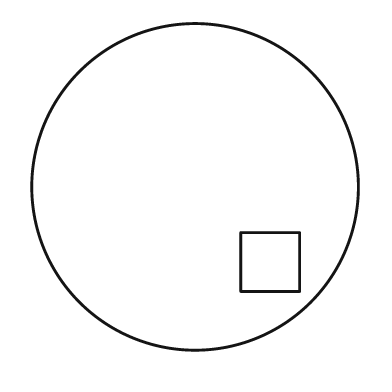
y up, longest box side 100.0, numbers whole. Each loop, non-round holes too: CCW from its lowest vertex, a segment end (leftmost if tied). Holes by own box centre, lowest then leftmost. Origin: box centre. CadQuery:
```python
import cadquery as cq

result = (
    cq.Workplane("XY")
    .moveTo(0.0, 0.0)
    .circle(50.0)
    .moveTo(14.0, -32.0)
    .lineTo(32.0, -32.0)
    .lineTo(32.0, -14.0)
    .lineTo(14.0, -14.0)
    .close()
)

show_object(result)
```